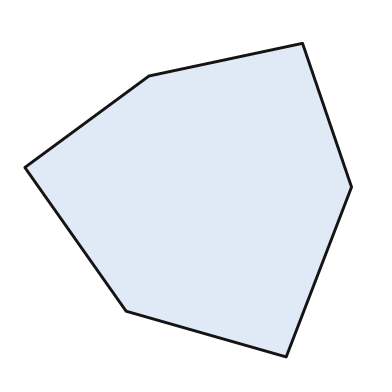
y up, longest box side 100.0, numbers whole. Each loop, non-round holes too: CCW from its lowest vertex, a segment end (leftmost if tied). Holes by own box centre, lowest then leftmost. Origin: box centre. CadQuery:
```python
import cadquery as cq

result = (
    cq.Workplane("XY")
    .moveTo(30.0, -48.0)
    .lineTo(50.0, 4.0)
    .lineTo(35.0, 48.0)
    .lineTo(-12.0, 38.0)
    .lineTo(-50.0, 10.0)
    .lineTo(-19.0, -34.0)
    .close()
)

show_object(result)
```